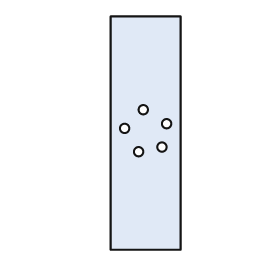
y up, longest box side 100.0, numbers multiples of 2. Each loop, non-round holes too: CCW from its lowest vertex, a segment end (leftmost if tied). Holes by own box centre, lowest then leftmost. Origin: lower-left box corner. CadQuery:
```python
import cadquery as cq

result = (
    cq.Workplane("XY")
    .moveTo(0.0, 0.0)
    .lineTo(30.0, 0.0)
    .lineTo(30.0, 100.0)
    .lineTo(0.0, 100.0)
    .close()
    .moveTo(12.0, 42.0)
    .circle(2.0)
    .moveTo(22.0, 44.0)
    .circle(2.0)
    .moveTo(6.0, 52.0)
    .circle(2.0)
    .moveTo(24.0, 54.0)
    .circle(2.0)
    .moveTo(14.0, 60.0)
    .circle(2.0)
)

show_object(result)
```